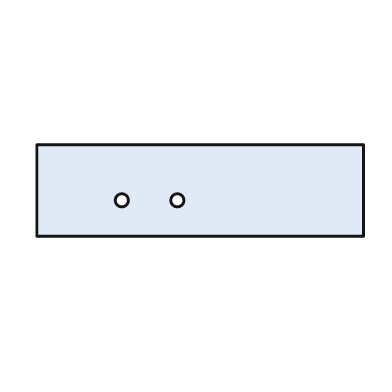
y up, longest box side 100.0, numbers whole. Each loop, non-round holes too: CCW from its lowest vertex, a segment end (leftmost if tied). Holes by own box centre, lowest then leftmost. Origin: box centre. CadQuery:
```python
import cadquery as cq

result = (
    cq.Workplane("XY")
    .moveTo(-50.0, -14.0)
    .lineTo(50.0, -14.0)
    .lineTo(50.0, 14.0)
    .lineTo(-50.0, 14.0)
    .close()
    .moveTo(-24.0, -3.0)
    .circle(2.0)
    .moveTo(-7.0, -3.0)
    .circle(2.0)
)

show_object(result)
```